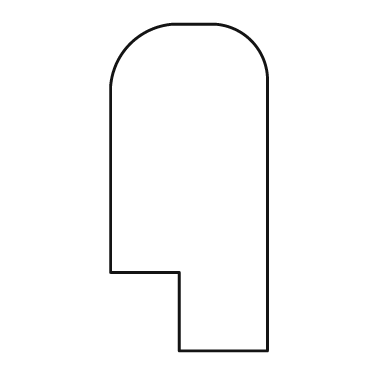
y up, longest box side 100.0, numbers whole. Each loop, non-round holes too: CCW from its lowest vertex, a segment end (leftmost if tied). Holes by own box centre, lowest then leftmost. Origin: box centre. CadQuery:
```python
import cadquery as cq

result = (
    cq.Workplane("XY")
    .moveTo(-3.0, -50.0)
    .lineTo(24.0, -50.0)
    .lineTo(24.0, 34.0)
    .threePointArc((19.0, 45.0), (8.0, 50.0))
    .lineTo(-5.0, 50.0)
    .threePointArc((-18.0, 44.0), (-24.0, 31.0))
    .lineTo(-24.0, -26.0)
    .lineTo(-3.0, -26.0)
    .close()
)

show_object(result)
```